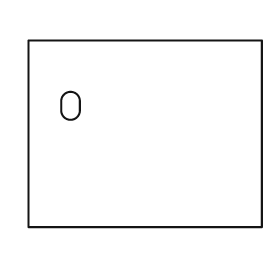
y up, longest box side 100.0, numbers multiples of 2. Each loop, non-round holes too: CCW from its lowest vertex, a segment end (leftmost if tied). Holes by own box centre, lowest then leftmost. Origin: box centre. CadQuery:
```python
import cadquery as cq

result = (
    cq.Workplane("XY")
    .moveTo(-50.0, -40.0)
    .lineTo(50.0, -40.0)
    .lineTo(50.0, 40.0)
    .lineTo(-50.0, 40.0)
    .close()
    .moveTo(-36.0, 10.0)
    .threePointArc((-32.0, 6.0), (-28.0, 10.0))
    .lineTo(-28.0, 14.0)
    .threePointArc((-32.0, 18.0), (-36.0, 14.0))
    .close()
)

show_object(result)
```